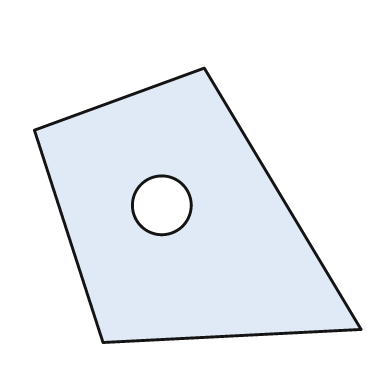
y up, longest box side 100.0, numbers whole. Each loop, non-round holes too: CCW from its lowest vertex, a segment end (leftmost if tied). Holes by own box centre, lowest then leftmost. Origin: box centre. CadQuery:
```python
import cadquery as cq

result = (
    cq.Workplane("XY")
    .moveTo(-29.0, -42.0)
    .lineTo(50.0, -38.0)
    .lineTo(2.0, 42.0)
    .lineTo(-50.0, 23.0)
    .close()
    .moveTo(-11.0, 0.0)
    .circle(9.0)
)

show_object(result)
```